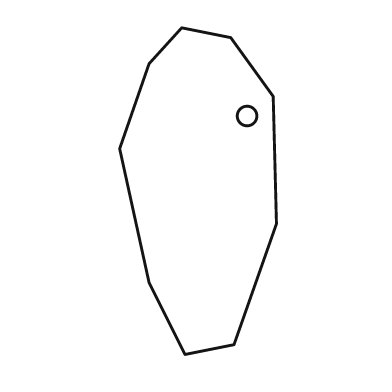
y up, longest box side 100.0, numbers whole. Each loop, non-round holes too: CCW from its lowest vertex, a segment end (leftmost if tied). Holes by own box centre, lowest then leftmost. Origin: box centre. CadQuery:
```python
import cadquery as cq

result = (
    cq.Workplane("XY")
    .moveTo(-4.0, -50.0)
    .lineTo(11.0, -47.0)
    .lineTo(24.0, -10.0)
    .lineTo(23.0, 29.0)
    .lineTo(10.0, 47.0)
    .lineTo(-5.0, 50.0)
    .lineTo(-15.0, 39.0)
    .lineTo(-24.0, 13.0)
    .lineTo(-15.0, -28.0)
    .close()
    .moveTo(15.0, 23.0)
    .circle(3.0)
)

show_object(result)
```